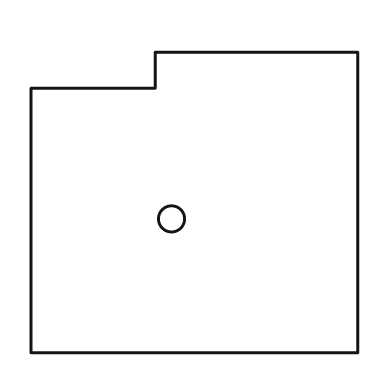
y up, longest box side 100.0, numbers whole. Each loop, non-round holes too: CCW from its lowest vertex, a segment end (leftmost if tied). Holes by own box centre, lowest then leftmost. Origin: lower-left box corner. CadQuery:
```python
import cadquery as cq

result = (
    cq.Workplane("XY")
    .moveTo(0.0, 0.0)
    .lineTo(100.0, 0.0)
    .lineTo(100.0, 92.0)
    .lineTo(38.0, 92.0)
    .lineTo(38.0, 81.0)
    .lineTo(0.0, 81.0)
    .close()
    .moveTo(43.0, 41.0)
    .circle(4.0)
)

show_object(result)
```